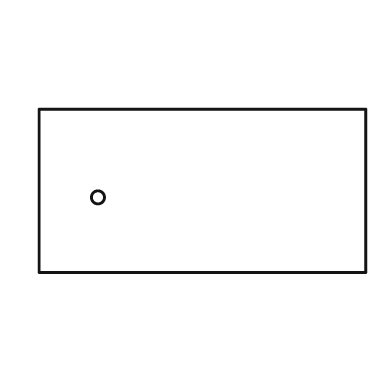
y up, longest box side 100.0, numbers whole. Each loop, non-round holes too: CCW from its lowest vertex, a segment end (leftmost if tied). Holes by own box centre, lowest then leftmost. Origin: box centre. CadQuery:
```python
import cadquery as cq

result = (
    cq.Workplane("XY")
    .moveTo(-50.0, -25.0)
    .lineTo(50.0, -25.0)
    .lineTo(50.0, 25.0)
    .lineTo(-50.0, 25.0)
    .close()
    .moveTo(-32.0, -2.0)
    .circle(2.0)
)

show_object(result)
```